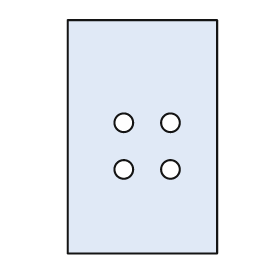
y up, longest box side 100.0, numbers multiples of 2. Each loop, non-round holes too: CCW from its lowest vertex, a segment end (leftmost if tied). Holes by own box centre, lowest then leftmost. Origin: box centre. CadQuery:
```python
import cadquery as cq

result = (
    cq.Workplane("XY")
    .moveTo(-32.0, -50.0)
    .lineTo(32.0, -50.0)
    .lineTo(32.0, 50.0)
    .lineTo(-32.0, 50.0)
    .close()
    .moveTo(-8.0, -14.0)
    .circle(4.0)
    .moveTo(12.0, -14.0)
    .circle(4.0)
    .moveTo(-8.0, 6.0)
    .circle(4.0)
    .moveTo(12.0, 6.0)
    .circle(4.0)
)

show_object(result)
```